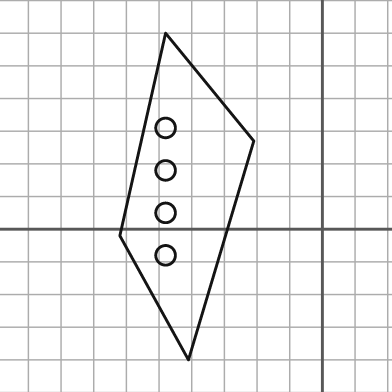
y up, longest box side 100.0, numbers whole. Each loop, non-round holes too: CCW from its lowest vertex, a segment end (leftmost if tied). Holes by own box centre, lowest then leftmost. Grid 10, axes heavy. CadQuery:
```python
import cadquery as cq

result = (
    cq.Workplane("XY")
    .moveTo(-41.0, -40.0)
    .lineTo(-21.0, 27.0)
    .lineTo(-48.0, 60.0)
    .lineTo(-62.0, -2.0)
    .close()
    .moveTo(-48.0, -8.0)
    .circle(3.0)
    .moveTo(-48.0, 5.0)
    .circle(3.0)
    .moveTo(-48.0, 18.0)
    .circle(3.0)
    .moveTo(-48.0, 31.0)
    .circle(3.0)
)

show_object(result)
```